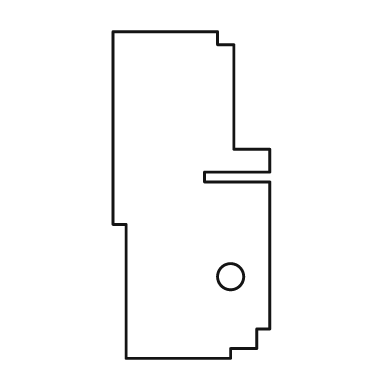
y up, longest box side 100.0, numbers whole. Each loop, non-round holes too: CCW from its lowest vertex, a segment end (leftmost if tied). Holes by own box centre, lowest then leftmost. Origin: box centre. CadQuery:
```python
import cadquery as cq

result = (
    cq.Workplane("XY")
    .moveTo(-20.0, -50.0)
    .lineTo(12.0, -50.0)
    .lineTo(12.0, -47.0)
    .lineTo(20.0, -47.0)
    .lineTo(20.0, -41.0)
    .lineTo(24.0, -41.0)
    .lineTo(24.0, 4.0)
    .lineTo(4.0, 4.0)
    .lineTo(4.0, 7.0)
    .lineTo(24.0, 7.0)
    .lineTo(24.0, 14.0)
    .lineTo(13.0, 14.0)
    .lineTo(13.0, 46.0)
    .lineTo(8.0, 46.0)
    .lineTo(8.0, 50.0)
    .lineTo(-24.0, 50.0)
    .lineTo(-24.0, -9.0)
    .lineTo(-20.0, -9.0)
    .close()
    .moveTo(12.0, -25.0)
    .circle(4.0)
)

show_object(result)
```